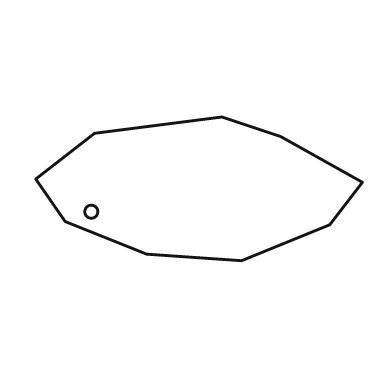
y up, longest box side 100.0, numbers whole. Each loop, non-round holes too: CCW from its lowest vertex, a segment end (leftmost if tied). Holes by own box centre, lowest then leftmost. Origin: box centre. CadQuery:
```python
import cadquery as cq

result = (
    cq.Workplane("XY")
    .moveTo(13.0, -22.0)
    .lineTo(40.0, -11.0)
    .lineTo(50.0, 2.0)
    .lineTo(25.0, 16.0)
    .lineTo(7.0, 22.0)
    .lineTo(-32.0, 17.0)
    .lineTo(-50.0, 3.0)
    .lineTo(-41.0, -10.0)
    .lineTo(-16.0, -20.0)
    .close()
    .moveTo(-33.0, -7.0)
    .circle(2.0)
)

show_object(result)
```